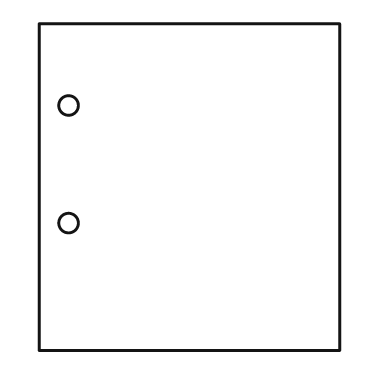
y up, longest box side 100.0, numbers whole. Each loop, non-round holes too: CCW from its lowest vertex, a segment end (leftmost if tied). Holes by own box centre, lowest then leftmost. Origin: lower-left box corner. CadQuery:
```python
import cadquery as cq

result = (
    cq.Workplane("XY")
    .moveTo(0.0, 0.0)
    .lineTo(92.0, 0.0)
    .lineTo(92.0, 100.0)
    .lineTo(0.0, 100.0)
    .close()
    .moveTo(9.0, 39.0)
    .circle(3.0)
    .moveTo(9.0, 75.0)
    .circle(3.0)
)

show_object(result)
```